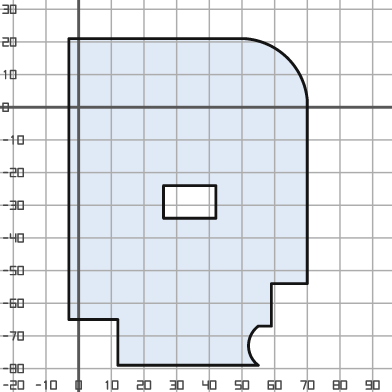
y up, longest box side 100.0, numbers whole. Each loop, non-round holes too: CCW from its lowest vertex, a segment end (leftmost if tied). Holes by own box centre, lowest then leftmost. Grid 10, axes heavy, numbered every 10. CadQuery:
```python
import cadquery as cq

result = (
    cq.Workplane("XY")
    .moveTo(12.0, -79.0)
    .lineTo(55.0, -79.0)
    .threePointArc((52.0, -73.0), (55.0, -67.0))
    .lineTo(59.0, -67.0)
    .lineTo(59.0, -54.0)
    .lineTo(70.0, -54.0)
    .lineTo(70.0, 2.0)
    .threePointArc((64.0, 15.0), (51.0, 21.0))
    .lineTo(-3.0, 21.0)
    .lineTo(-3.0, -65.0)
    .lineTo(12.0, -65.0)
    .close()
    .moveTo(26.0, -34.0)
    .lineTo(42.0, -34.0)
    .lineTo(42.0, -24.0)
    .lineTo(26.0, -24.0)
    .close()
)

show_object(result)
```